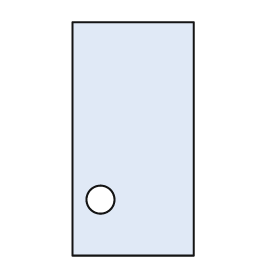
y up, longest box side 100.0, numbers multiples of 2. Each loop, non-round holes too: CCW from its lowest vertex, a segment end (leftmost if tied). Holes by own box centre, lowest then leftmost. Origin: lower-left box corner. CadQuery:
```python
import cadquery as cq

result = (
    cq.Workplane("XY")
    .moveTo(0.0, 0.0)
    .lineTo(52.0, 0.0)
    .lineTo(52.0, 100.0)
    .lineTo(0.0, 100.0)
    .close()
    .moveTo(12.0, 24.0)
    .circle(6.0)
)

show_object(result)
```